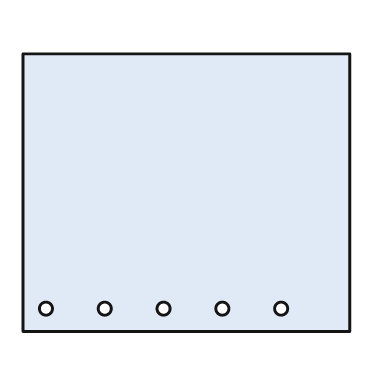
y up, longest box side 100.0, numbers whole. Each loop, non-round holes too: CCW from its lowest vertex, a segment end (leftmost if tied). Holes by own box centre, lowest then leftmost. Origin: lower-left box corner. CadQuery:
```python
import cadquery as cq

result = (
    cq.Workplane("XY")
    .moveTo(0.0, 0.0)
    .lineTo(100.0, 0.0)
    .lineTo(100.0, 85.0)
    .lineTo(0.0, 85.0)
    .close()
    .moveTo(7.0, 7.0)
    .circle(2.0)
    .moveTo(25.0, 7.0)
    .circle(2.0)
    .moveTo(43.0, 7.0)
    .circle(2.0)
    .moveTo(61.0, 7.0)
    .circle(2.0)
    .moveTo(79.0, 7.0)
    .circle(2.0)
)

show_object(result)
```